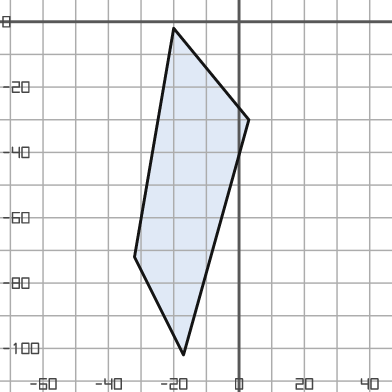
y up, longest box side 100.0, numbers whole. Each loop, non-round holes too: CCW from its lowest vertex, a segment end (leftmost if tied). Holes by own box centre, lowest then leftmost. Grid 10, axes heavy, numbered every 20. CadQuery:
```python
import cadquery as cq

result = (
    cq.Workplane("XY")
    .moveTo(-17.0, -102.0)
    .lineTo(3.0, -30.0)
    .lineTo(-20.0, -2.0)
    .lineTo(-32.0, -72.0)
    .close()
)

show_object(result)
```